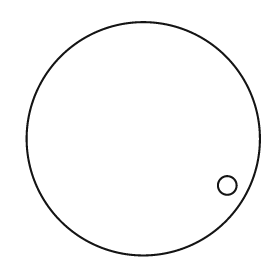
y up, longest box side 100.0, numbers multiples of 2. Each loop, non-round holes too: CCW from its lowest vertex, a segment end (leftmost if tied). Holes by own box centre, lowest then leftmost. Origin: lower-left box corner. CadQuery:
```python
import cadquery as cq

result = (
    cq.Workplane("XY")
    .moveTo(50.0, 50.0)
    .circle(50.0)
    .moveTo(86.0, 30.0)
    .circle(4.0)
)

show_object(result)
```